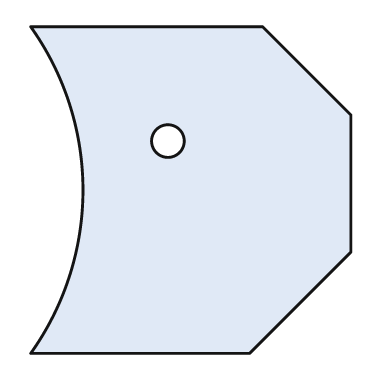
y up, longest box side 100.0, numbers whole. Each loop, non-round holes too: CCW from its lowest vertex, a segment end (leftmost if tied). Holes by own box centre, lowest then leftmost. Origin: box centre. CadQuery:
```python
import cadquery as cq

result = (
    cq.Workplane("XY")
    .moveTo(-49.0, -50.0)
    .lineTo(18.0, -50.0)
    .lineTo(49.0, -19.0)
    .lineTo(49.0, 23.0)
    .lineTo(22.0, 50.0)
    .lineTo(-49.0, 50.0)
    .threePointArc((-33.0, 0.0), (-49.0, -50.0))
    .close()
    .moveTo(-7.0, 15.0)
    .circle(5.0)
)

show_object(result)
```